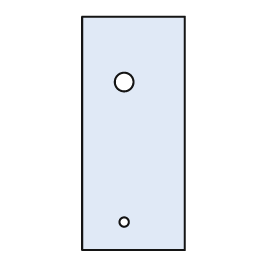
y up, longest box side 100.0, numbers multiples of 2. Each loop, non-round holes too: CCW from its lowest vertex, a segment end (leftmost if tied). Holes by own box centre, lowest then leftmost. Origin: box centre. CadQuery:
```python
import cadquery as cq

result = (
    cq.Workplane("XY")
    .moveTo(-22.0, -50.0)
    .lineTo(22.0, -50.0)
    .lineTo(22.0, 50.0)
    .lineTo(-22.0, 50.0)
    .close()
    .moveTo(-4.0, -38.0)
    .circle(2.0)
    .moveTo(-4.0, 22.0)
    .circle(4.0)
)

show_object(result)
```